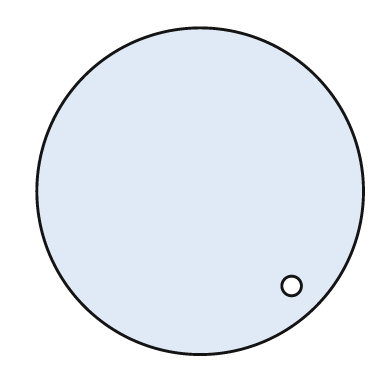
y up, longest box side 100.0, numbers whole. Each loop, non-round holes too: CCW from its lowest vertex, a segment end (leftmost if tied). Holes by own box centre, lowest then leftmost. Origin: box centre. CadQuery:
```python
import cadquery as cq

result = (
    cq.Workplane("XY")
    .moveTo(0.0, 0.0)
    .circle(50.0)
    .moveTo(28.0, -29.0)
    .circle(3.0)
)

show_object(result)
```